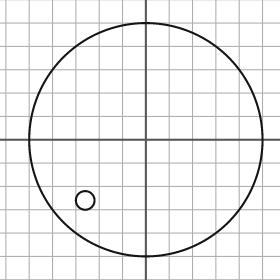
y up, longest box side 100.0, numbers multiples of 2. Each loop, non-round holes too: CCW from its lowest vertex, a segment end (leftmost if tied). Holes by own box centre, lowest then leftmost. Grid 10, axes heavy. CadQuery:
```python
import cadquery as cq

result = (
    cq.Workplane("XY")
    .moveTo(0.0, 0.0)
    .circle(50.0)
    .moveTo(-26.0, -26.0)
    .circle(4.0)
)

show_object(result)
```